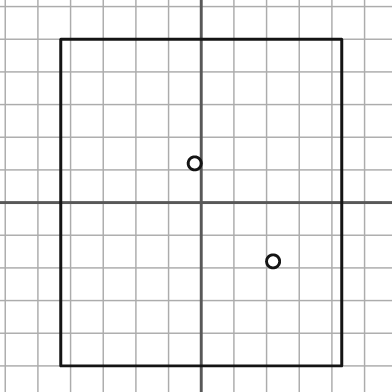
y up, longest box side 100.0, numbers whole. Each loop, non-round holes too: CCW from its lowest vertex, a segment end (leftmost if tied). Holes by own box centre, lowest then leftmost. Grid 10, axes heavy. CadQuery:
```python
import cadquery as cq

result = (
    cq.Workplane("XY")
    .moveTo(-43.0, -50.0)
    .lineTo(43.0, -50.0)
    .lineTo(43.0, 50.0)
    .lineTo(-43.0, 50.0)
    .close()
    .moveTo(22.0, -18.0)
    .circle(2.0)
    .moveTo(-2.0, 12.0)
    .circle(2.0)
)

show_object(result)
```